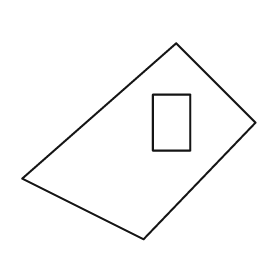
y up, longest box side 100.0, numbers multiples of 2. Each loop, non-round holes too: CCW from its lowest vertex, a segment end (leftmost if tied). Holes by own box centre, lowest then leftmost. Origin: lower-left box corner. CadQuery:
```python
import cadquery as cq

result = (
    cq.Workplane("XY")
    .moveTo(52.0, 0.0)
    .lineTo(100.0, 50.0)
    .lineTo(66.0, 84.0)
    .lineTo(0.0, 26.0)
    .close()
    .moveTo(56.0, 38.0)
    .lineTo(72.0, 38.0)
    .lineTo(72.0, 62.0)
    .lineTo(56.0, 62.0)
    .close()
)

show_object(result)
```